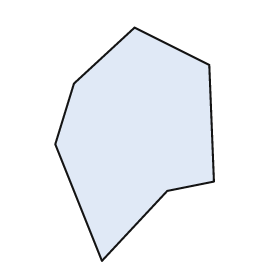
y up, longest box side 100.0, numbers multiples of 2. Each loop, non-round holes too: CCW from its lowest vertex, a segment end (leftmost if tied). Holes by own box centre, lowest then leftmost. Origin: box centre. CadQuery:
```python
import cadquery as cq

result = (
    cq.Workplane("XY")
    .moveTo(-14.0, -50.0)
    .lineTo(14.0, -20.0)
    .lineTo(34.0, -16.0)
    .lineTo(32.0, 34.0)
    .lineTo(0.0, 50.0)
    .lineTo(-26.0, 26.0)
    .lineTo(-34.0, 0.0)
    .close()
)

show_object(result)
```